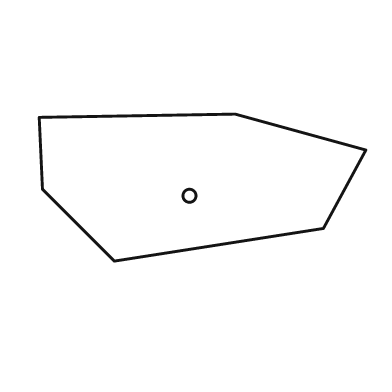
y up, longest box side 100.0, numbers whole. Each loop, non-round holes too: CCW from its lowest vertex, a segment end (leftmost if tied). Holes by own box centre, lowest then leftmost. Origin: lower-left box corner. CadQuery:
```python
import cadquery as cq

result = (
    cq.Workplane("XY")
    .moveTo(23.0, 0.0)
    .lineTo(87.0, 10.0)
    .lineTo(100.0, 34.0)
    .lineTo(60.0, 45.0)
    .lineTo(0.0, 44.0)
    .lineTo(1.0, 22.0)
    .close()
    .moveTo(46.0, 20.0)
    .circle(2.0)
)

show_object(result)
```